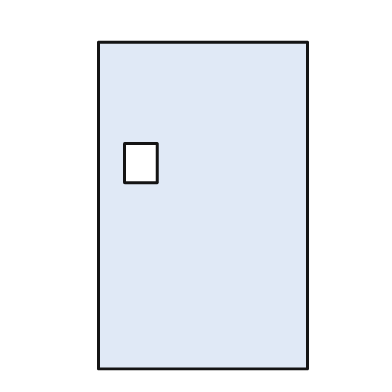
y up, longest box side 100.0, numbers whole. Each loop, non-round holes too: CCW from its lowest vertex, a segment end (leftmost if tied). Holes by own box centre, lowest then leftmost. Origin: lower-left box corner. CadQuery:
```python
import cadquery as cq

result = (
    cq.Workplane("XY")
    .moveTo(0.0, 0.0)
    .lineTo(64.0, 0.0)
    .lineTo(64.0, 100.0)
    .lineTo(0.0, 100.0)
    .close()
    .moveTo(8.0, 57.0)
    .lineTo(18.0, 57.0)
    .lineTo(18.0, 69.0)
    .lineTo(8.0, 69.0)
    .close()
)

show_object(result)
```